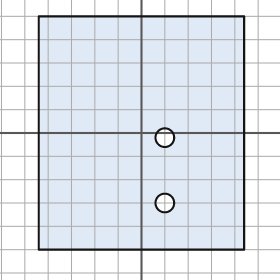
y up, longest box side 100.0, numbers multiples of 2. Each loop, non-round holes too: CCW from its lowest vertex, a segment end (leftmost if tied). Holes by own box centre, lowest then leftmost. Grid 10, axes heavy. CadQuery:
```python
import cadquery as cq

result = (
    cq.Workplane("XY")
    .moveTo(-44.0, -50.0)
    .lineTo(44.0, -50.0)
    .lineTo(44.0, 50.0)
    .lineTo(-44.0, 50.0)
    .close()
    .moveTo(10.0, -30.0)
    .circle(4.0)
    .moveTo(10.0, -2.0)
    .circle(4.0)
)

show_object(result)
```